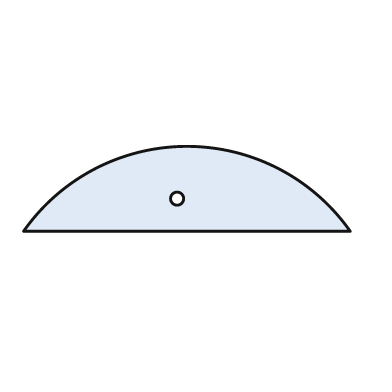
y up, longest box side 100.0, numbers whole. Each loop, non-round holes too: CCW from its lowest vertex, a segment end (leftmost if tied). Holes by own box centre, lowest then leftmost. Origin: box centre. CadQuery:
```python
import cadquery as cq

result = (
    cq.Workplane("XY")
    .moveTo(-50.0, -13.0)
    .lineTo(50.0, -13.0)
    .threePointArc((0.0, 13.0), (-50.0, -13.0))
    .close()
    .moveTo(-3.0, -3.0)
    .circle(2.0)
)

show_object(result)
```